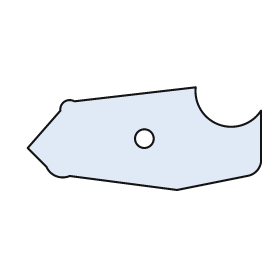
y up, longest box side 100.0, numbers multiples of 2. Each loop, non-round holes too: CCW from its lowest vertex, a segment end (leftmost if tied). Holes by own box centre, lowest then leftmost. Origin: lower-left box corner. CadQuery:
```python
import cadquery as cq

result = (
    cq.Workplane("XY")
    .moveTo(64.0, 0.0)
    .lineTo(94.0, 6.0)
    .threePointArc((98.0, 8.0), (100.0, 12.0))
    .lineTo(100.0, 34.0)
    .threePointArc((82.0, 28.0), (72.0, 44.0))
    .lineTo(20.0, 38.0)
    .threePointArc((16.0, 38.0), (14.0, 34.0))
    .lineTo(0.0, 18.0)
    .lineTo(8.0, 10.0)
    .threePointArc((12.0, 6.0), (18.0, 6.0))
    .close()
    .moveTo(50.0, 22.0)
    .circle(4.0)
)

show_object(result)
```